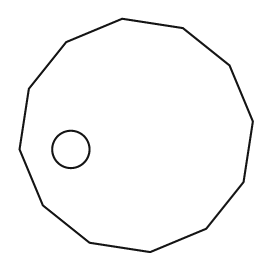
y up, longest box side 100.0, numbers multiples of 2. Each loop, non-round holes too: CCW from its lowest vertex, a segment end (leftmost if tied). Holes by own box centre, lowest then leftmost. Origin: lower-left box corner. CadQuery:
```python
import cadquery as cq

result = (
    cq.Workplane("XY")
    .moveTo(56.0, 0.0)
    .lineTo(80.0, 10.0)
    .lineTo(96.0, 30.0)
    .lineTo(100.0, 56.0)
    .lineTo(90.0, 80.0)
    .lineTo(70.0, 96.0)
    .lineTo(44.0, 100.0)
    .lineTo(20.0, 90.0)
    .lineTo(4.0, 70.0)
    .lineTo(0.0, 44.0)
    .lineTo(10.0, 20.0)
    .lineTo(30.0, 4.0)
    .close()
    .moveTo(22.0, 44.0)
    .circle(8.0)
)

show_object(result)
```